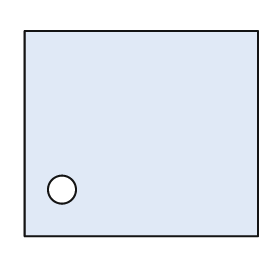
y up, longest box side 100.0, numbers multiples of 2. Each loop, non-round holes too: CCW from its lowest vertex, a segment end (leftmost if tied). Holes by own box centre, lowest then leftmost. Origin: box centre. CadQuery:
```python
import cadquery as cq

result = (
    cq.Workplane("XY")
    .moveTo(-50.0, -44.0)
    .lineTo(50.0, -44.0)
    .lineTo(50.0, 44.0)
    .lineTo(-50.0, 44.0)
    .close()
    .moveTo(-34.0, -24.0)
    .circle(6.0)
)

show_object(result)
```